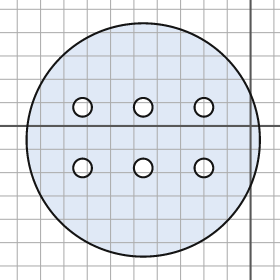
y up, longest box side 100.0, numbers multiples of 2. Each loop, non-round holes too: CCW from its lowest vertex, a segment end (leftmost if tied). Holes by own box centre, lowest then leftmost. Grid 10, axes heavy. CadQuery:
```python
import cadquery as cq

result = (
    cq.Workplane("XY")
    .moveTo(-46.0, -6.0)
    .circle(50.0)
    .moveTo(-72.0, -18.0)
    .circle(4.0)
    .moveTo(-46.0, -18.0)
    .circle(4.0)
    .moveTo(-20.0, -18.0)
    .circle(4.0)
    .moveTo(-72.0, 8.0)
    .circle(4.0)
    .moveTo(-46.0, 8.0)
    .circle(4.0)
    .moveTo(-20.0, 8.0)
    .circle(4.0)
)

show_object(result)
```